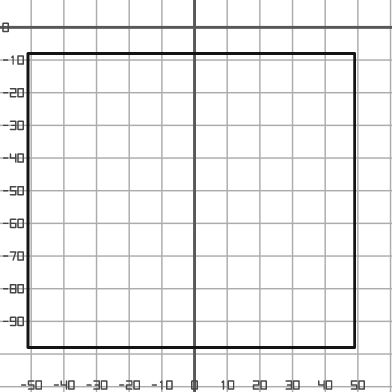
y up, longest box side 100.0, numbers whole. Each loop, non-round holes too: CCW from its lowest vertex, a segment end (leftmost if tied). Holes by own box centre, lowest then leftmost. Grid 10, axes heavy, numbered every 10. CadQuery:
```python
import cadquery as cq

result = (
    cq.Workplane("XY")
    .moveTo(-51.0, -98.0)
    .lineTo(49.0, -98.0)
    .lineTo(49.0, -8.0)
    .lineTo(-51.0, -8.0)
    .close()
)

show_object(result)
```